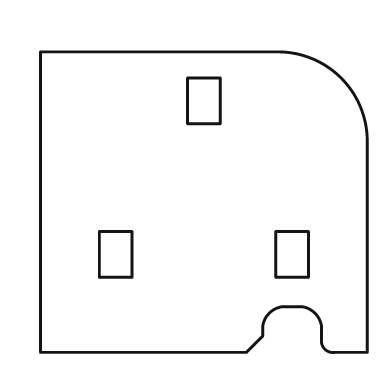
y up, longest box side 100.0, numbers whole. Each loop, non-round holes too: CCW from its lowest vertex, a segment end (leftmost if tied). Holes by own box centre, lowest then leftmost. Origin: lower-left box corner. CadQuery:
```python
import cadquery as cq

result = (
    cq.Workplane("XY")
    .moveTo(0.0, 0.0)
    .lineTo(63.0, 0.0)
    .lineTo(68.0, 5.0)
    .lineTo(68.0, 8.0)
    .threePointArc((70.0, 12.0), (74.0, 14.0))
    .lineTo(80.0, 14.0)
    .threePointArc((84.0, 12.0), (86.0, 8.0))
    .lineTo(86.0, 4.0)
    .threePointArc((87.0, 1.0), (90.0, 0.0))
    .lineTo(100.0, 0.0)
    .lineTo(100.0, 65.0)
    .threePointArc((92.0, 84.0), (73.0, 92.0))
    .lineTo(0.0, 92.0)
    .close()
    .moveTo(18.0, 23.0)
    .lineTo(28.0, 23.0)
    .lineTo(28.0, 37.0)
    .lineTo(18.0, 37.0)
    .close()
    .moveTo(72.0, 23.0)
    .lineTo(82.0, 23.0)
    .lineTo(82.0, 37.0)
    .lineTo(72.0, 37.0)
    .close()
    .moveTo(45.0, 70.0)
    .lineTo(55.0, 70.0)
    .lineTo(55.0, 84.0)
    .lineTo(45.0, 84.0)
    .close()
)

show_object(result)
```